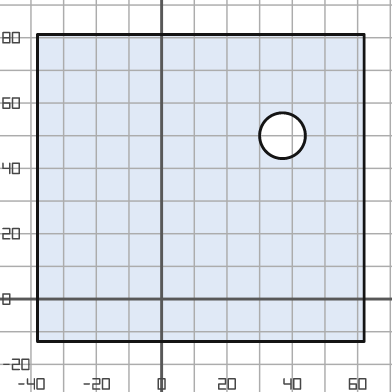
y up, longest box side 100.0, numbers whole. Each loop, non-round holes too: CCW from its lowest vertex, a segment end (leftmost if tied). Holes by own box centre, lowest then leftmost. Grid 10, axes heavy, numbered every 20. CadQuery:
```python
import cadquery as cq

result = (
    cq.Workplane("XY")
    .moveTo(-38.0, -13.0)
    .lineTo(62.0, -13.0)
    .lineTo(62.0, 81.0)
    .lineTo(-38.0, 81.0)
    .close()
    .moveTo(37.0, 50.0)
    .circle(7.0)
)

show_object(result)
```